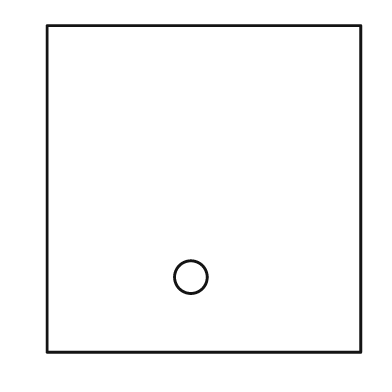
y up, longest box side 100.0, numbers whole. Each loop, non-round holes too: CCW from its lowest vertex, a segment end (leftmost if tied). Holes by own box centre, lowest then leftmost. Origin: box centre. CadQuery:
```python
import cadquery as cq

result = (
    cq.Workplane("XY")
    .moveTo(-48.0, -50.0)
    .lineTo(48.0, -50.0)
    .lineTo(48.0, 50.0)
    .lineTo(-48.0, 50.0)
    .close()
    .moveTo(-4.0, -27.0)
    .circle(5.0)
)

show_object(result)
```